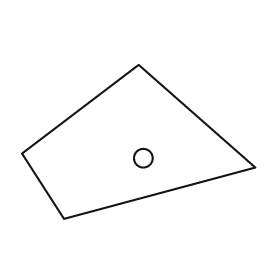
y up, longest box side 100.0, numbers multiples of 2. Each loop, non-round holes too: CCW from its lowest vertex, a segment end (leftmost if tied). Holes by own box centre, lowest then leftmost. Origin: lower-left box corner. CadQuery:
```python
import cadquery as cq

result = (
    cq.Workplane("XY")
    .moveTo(18.0, 0.0)
    .lineTo(100.0, 22.0)
    .lineTo(50.0, 66.0)
    .lineTo(0.0, 28.0)
    .close()
    .moveTo(52.0, 26.0)
    .circle(4.0)
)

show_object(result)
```